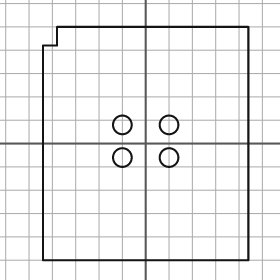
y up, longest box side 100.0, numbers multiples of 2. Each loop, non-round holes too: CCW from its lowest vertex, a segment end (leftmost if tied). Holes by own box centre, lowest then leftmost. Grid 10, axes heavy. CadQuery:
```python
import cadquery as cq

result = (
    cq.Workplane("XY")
    .moveTo(-44.0, -50.0)
    .lineTo(44.0, -50.0)
    .lineTo(44.0, 50.0)
    .lineTo(-38.0, 50.0)
    .lineTo(-38.0, 42.0)
    .lineTo(-44.0, 42.0)
    .close()
    .moveTo(-10.0, -6.0)
    .circle(4.0)
    .moveTo(10.0, -6.0)
    .circle(4.0)
    .moveTo(-10.0, 8.0)
    .circle(4.0)
    .moveTo(10.0, 8.0)
    .circle(4.0)
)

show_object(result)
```